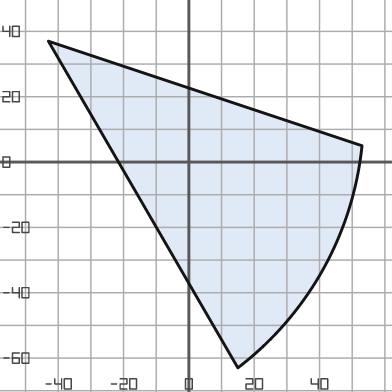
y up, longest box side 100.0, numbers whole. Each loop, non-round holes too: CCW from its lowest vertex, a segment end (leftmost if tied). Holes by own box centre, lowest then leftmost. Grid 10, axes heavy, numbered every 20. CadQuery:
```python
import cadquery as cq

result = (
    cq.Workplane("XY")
    .moveTo(15.0, -63.0)
    .threePointArc((41.0, -33.0), (53.0, 5.0))
    .lineTo(-43.0, 37.0)
    .close()
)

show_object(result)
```